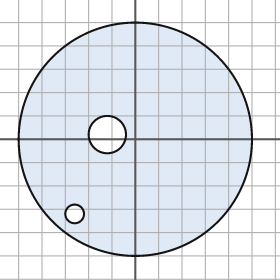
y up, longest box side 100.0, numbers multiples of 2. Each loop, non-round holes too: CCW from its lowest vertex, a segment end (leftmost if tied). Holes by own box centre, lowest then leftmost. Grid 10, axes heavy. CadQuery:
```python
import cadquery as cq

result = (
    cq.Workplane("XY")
    .moveTo(0.0, 0.0)
    .circle(50.0)
    .moveTo(-26.0, -32.0)
    .circle(4.0)
    .moveTo(-12.0, 2.0)
    .circle(8.0)
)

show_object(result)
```